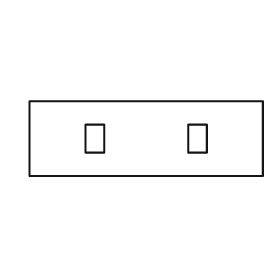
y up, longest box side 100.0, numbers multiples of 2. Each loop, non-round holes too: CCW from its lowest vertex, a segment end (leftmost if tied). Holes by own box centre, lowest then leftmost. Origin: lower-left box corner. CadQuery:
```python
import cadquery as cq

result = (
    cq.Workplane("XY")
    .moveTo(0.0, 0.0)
    .lineTo(100.0, 0.0)
    .lineTo(100.0, 32.0)
    .lineTo(0.0, 32.0)
    .close()
    .moveTo(24.0, 10.0)
    .lineTo(32.0, 10.0)
    .lineTo(32.0, 22.0)
    .lineTo(24.0, 22.0)
    .close()
    .moveTo(68.0, 10.0)
    .lineTo(76.0, 10.0)
    .lineTo(76.0, 22.0)
    .lineTo(68.0, 22.0)
    .close()
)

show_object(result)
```